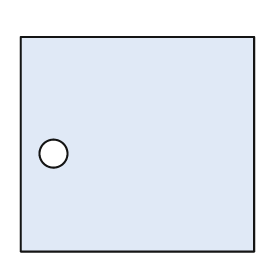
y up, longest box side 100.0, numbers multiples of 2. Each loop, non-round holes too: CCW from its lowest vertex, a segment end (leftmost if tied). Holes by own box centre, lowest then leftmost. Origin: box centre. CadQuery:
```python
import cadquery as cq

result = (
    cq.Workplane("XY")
    .moveTo(-50.0, -46.0)
    .lineTo(50.0, -46.0)
    .lineTo(50.0, 46.0)
    .lineTo(-50.0, 46.0)
    .close()
    .moveTo(-36.0, -4.0)
    .circle(6.0)
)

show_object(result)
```